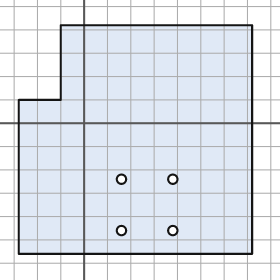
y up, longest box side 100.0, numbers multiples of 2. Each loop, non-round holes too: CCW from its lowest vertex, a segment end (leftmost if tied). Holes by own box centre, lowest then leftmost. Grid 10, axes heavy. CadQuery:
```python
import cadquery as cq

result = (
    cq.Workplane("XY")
    .moveTo(-28.0, -56.0)
    .lineTo(72.0, -56.0)
    .lineTo(72.0, 42.0)
    .lineTo(-10.0, 42.0)
    .lineTo(-10.0, 10.0)
    .lineTo(-28.0, 10.0)
    .close()
    .moveTo(16.0, -46.0)
    .circle(2.0)
    .moveTo(38.0, -46.0)
    .circle(2.0)
    .moveTo(16.0, -24.0)
    .circle(2.0)
    .moveTo(38.0, -24.0)
    .circle(2.0)
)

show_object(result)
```